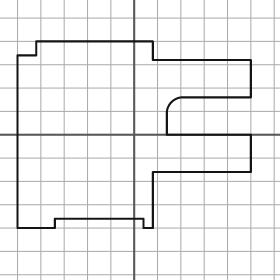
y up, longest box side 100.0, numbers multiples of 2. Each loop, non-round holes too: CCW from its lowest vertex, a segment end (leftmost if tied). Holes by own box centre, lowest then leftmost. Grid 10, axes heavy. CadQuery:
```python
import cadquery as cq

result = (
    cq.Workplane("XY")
    .moveTo(-50.0, -40.0)
    .lineTo(-34.0, -40.0)
    .lineTo(-34.0, -36.0)
    .lineTo(4.0, -36.0)
    .lineTo(4.0, -40.0)
    .lineTo(8.0, -40.0)
    .lineTo(8.0, -16.0)
    .lineTo(50.0, -16.0)
    .lineTo(50.0, 0.0)
    .lineTo(14.0, 0.0)
    .lineTo(14.0, 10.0)
    .threePointArc((16.0, 14.0), (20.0, 16.0))
    .lineTo(50.0, 16.0)
    .lineTo(50.0, 32.0)
    .lineTo(8.0, 32.0)
    .lineTo(8.0, 40.0)
    .lineTo(-42.0, 40.0)
    .lineTo(-42.0, 34.0)
    .lineTo(-50.0, 34.0)
    .close()
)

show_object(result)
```